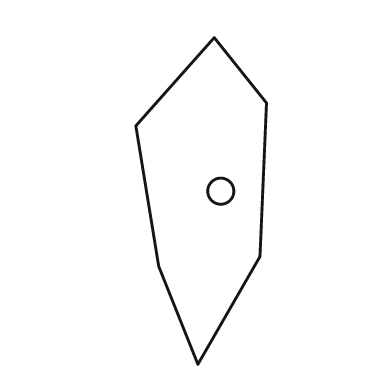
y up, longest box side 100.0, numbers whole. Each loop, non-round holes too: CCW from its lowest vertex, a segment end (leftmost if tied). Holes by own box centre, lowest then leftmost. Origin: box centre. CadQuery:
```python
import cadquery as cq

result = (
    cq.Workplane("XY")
    .moveTo(-1.0, -50.0)
    .lineTo(18.0, -17.0)
    .lineTo(20.0, 30.0)
    .lineTo(4.0, 50.0)
    .lineTo(-20.0, 23.0)
    .lineTo(-13.0, -20.0)
    .close()
    .moveTo(6.0, 3.0)
    .circle(4.0)
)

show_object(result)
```